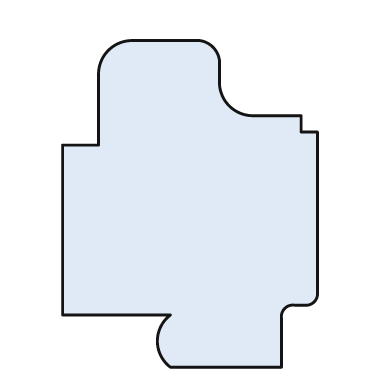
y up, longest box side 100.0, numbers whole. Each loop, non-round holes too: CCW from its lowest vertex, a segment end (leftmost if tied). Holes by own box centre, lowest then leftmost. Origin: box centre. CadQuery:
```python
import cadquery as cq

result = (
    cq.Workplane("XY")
    .moveTo(-6.0, -50.0)
    .lineTo(28.0, -50.0)
    .lineTo(28.0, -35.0)
    .threePointArc((29.0, -32.0), (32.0, -31.0))
    .lineTo(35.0, -31.0)
    .threePointArc((38.0, -30.0), (39.0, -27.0))
    .lineTo(39.0, 22.0)
    .lineTo(34.0, 22.0)
    .lineTo(34.0, 27.0)
    .lineTo(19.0, 27.0)
    .threePointArc((12.0, 30.0), (9.0, 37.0))
    .lineTo(9.0, 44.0)
    .threePointArc((7.0, 48.0), (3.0, 50.0))
    .lineTo(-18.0, 50.0)
    .threePointArc((-25.0, 47.0), (-28.0, 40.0))
    .lineTo(-28.0, 18.0)
    .lineTo(-39.0, 18.0)
    .lineTo(-39.0, -34.0)
    .lineTo(-6.0, -34.0)
    .threePointArc((-10.0, -42.0), (-6.0, -50.0))
    .close()
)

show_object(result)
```